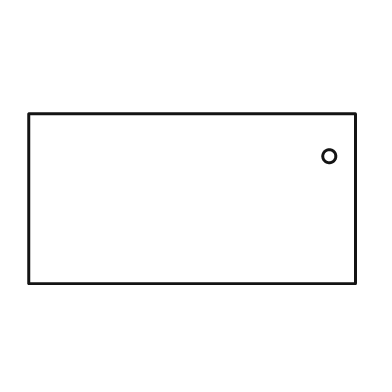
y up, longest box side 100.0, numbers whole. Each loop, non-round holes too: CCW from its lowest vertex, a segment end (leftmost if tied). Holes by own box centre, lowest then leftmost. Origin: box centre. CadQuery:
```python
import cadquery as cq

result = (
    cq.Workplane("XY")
    .moveTo(-50.0, -26.0)
    .lineTo(50.0, -26.0)
    .lineTo(50.0, 26.0)
    .lineTo(-50.0, 26.0)
    .close()
    .moveTo(42.0, 13.0)
    .circle(2.0)
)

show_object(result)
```